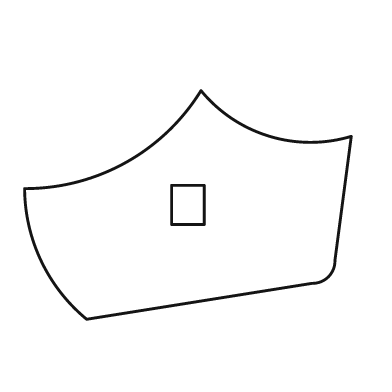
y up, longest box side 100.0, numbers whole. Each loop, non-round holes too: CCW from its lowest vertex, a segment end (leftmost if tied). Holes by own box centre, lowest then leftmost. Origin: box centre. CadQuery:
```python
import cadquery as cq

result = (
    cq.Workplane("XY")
    .moveTo(-31.0, -35.0)
    .lineTo(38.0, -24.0)
    .threePointArc((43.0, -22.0), (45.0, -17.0))
    .lineTo(50.0, 21.0)
    .threePointArc((25.0, 21.0), (4.0, 35.0))
    .threePointArc((-19.0, 13.0), (-50.0, 5.0))
    .threePointArc((-45.0, -17.0), (-31.0, -35.0))
    .close()
    .moveTo(-5.0, -6.0)
    .lineTo(5.0, -6.0)
    .lineTo(5.0, 6.0)
    .lineTo(-5.0, 6.0)
    .close()
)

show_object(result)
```